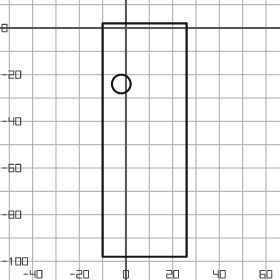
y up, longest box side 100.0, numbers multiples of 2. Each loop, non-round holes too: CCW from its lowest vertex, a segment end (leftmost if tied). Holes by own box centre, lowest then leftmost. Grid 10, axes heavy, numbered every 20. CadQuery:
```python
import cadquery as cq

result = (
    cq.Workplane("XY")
    .moveTo(-10.0, -98.0)
    .lineTo(26.0, -98.0)
    .lineTo(26.0, 2.0)
    .lineTo(-10.0, 2.0)
    .close()
    .moveTo(-2.0, -24.0)
    .circle(4.0)
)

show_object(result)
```